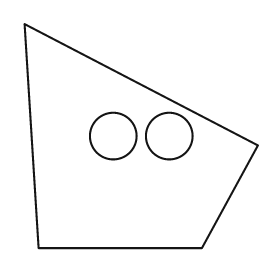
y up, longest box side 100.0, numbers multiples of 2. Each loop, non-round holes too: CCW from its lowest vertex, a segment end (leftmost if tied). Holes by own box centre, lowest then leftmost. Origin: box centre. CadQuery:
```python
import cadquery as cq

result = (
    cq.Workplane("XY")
    .moveTo(-44.0, -48.0)
    .lineTo(26.0, -48.0)
    .lineTo(50.0, -4.0)
    .lineTo(-50.0, 48.0)
    .close()
    .moveTo(-12.0, 0.0)
    .circle(10.0)
    .moveTo(12.0, 0.0)
    .circle(10.0)
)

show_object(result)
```